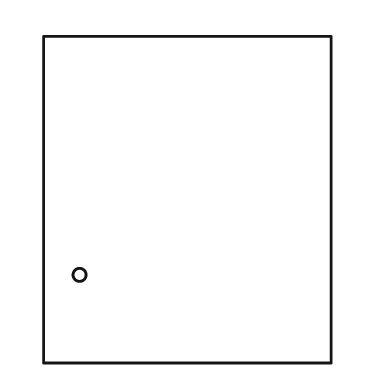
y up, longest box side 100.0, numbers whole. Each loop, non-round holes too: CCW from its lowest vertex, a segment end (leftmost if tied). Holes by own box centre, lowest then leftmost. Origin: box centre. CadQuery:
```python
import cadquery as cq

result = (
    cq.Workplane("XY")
    .moveTo(-44.0, -50.0)
    .lineTo(44.0, -50.0)
    .lineTo(44.0, 50.0)
    .lineTo(-44.0, 50.0)
    .close()
    .moveTo(-33.0, -23.0)
    .circle(2.0)
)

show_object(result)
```